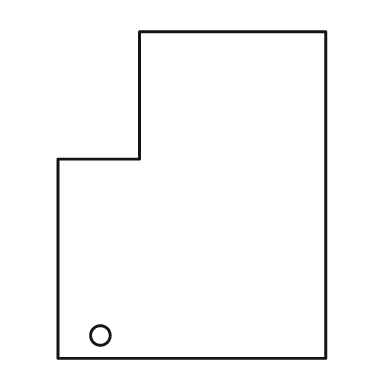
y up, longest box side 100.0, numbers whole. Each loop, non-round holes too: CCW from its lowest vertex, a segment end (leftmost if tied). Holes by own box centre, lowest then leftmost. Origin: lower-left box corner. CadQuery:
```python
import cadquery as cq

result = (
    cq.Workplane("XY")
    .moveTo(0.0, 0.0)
    .lineTo(82.0, 0.0)
    .lineTo(82.0, 100.0)
    .lineTo(25.0, 100.0)
    .lineTo(25.0, 61.0)
    .lineTo(0.0, 61.0)
    .close()
    .moveTo(13.0, 7.0)
    .circle(3.0)
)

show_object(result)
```